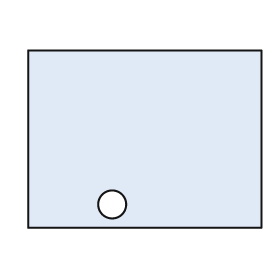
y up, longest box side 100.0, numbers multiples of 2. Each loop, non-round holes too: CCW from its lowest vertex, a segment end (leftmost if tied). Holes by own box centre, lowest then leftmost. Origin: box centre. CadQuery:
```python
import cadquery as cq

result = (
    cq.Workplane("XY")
    .moveTo(-50.0, -38.0)
    .lineTo(50.0, -38.0)
    .lineTo(50.0, 38.0)
    .lineTo(-50.0, 38.0)
    .close()
    .moveTo(-14.0, -28.0)
    .circle(6.0)
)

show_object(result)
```